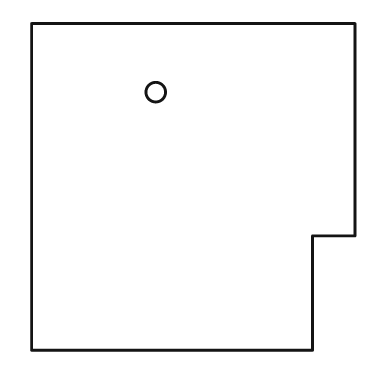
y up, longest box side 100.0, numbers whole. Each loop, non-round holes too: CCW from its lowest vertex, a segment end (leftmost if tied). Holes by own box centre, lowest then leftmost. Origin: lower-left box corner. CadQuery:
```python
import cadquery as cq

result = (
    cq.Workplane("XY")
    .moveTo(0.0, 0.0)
    .lineTo(86.0, 0.0)
    .lineTo(86.0, 35.0)
    .lineTo(99.0, 35.0)
    .lineTo(99.0, 100.0)
    .lineTo(0.0, 100.0)
    .close()
    .moveTo(38.0, 79.0)
    .circle(3.0)
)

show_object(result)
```